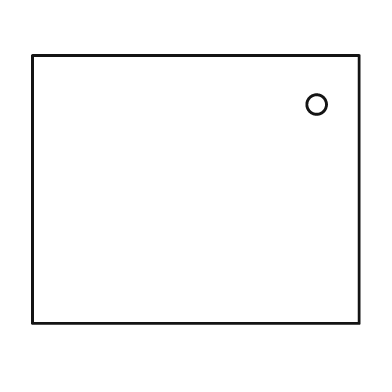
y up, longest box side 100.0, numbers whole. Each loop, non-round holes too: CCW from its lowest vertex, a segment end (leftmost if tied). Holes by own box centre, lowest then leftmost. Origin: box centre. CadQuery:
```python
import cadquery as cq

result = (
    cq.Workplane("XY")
    .moveTo(-50.0, -41.0)
    .lineTo(50.0, -41.0)
    .lineTo(50.0, 41.0)
    .lineTo(-50.0, 41.0)
    .close()
    .moveTo(37.0, 26.0)
    .circle(3.0)
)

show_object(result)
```